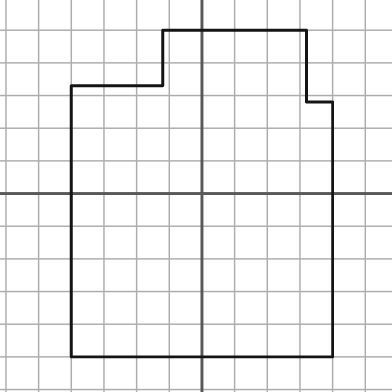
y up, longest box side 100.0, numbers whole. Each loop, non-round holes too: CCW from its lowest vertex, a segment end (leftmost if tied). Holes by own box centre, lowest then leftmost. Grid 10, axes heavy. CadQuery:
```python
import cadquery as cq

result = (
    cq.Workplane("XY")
    .moveTo(-40.0, -50.0)
    .lineTo(40.0, -50.0)
    .lineTo(40.0, 28.0)
    .lineTo(32.0, 28.0)
    .lineTo(32.0, 50.0)
    .lineTo(-12.0, 50.0)
    .lineTo(-12.0, 33.0)
    .lineTo(-40.0, 33.0)
    .close()
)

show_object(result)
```